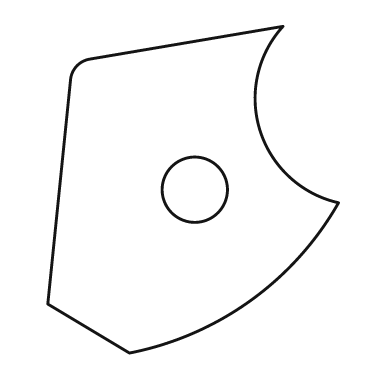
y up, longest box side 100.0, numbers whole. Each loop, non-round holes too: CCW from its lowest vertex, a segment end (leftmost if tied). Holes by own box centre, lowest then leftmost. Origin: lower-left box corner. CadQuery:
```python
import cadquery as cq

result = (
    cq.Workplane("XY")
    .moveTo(25.0, 0.0)
    .threePointArc((62.0, 16.0), (89.0, 46.0))
    .threePointArc((65.0, 68.0), (72.0, 100.0))
    .lineTo(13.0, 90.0)
    .threePointArc((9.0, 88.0), (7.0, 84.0))
    .lineTo(0.0, 15.0)
    .close()
    .moveTo(45.0, 50.0)
    .circle(10.0)
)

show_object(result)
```